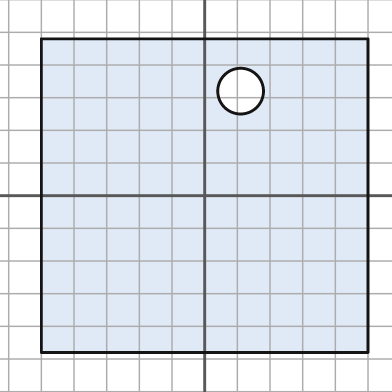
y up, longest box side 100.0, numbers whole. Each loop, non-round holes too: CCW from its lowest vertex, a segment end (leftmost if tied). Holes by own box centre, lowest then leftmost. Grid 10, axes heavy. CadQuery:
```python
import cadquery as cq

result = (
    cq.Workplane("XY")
    .moveTo(-50.0, -48.0)
    .lineTo(50.0, -48.0)
    .lineTo(50.0, 48.0)
    .lineTo(-50.0, 48.0)
    .close()
    .moveTo(11.0, 32.0)
    .circle(7.0)
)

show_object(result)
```